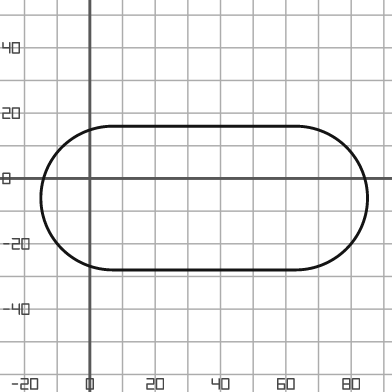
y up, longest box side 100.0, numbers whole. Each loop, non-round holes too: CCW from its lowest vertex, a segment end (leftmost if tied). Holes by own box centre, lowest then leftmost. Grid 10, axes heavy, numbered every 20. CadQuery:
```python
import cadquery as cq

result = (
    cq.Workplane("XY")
    .moveTo(7.0, -28.0)
    .lineTo(63.0, -28.0)
    .threePointArc((85.0, -6.0), (63.0, 16.0))
    .lineTo(7.0, 16.0)
    .threePointArc((-15.0, -6.0), (7.0, -28.0))
    .close()
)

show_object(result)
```